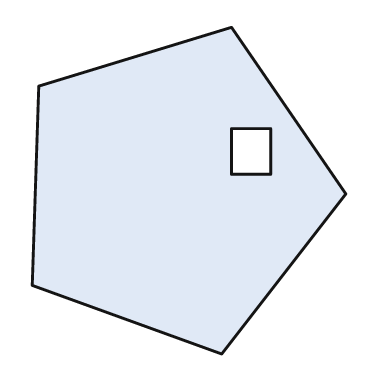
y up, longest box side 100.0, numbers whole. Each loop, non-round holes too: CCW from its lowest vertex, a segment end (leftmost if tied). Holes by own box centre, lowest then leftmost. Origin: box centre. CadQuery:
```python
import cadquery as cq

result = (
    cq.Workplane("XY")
    .moveTo(10.0, -50.0)
    .lineTo(48.0, -1.0)
    .lineTo(13.0, 50.0)
    .lineTo(-46.0, 32.0)
    .lineTo(-48.0, -29.0)
    .close()
    .moveTo(13.0, 5.0)
    .lineTo(25.0, 5.0)
    .lineTo(25.0, 19.0)
    .lineTo(13.0, 19.0)
    .close()
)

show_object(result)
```